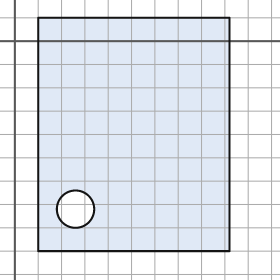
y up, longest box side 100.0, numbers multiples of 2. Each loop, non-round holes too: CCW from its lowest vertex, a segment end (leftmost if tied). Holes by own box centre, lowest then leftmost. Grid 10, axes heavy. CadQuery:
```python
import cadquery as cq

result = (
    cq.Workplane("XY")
    .moveTo(10.0, -90.0)
    .lineTo(92.0, -90.0)
    .lineTo(92.0, 10.0)
    .lineTo(10.0, 10.0)
    .close()
    .moveTo(26.0, -72.0)
    .circle(8.0)
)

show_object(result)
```